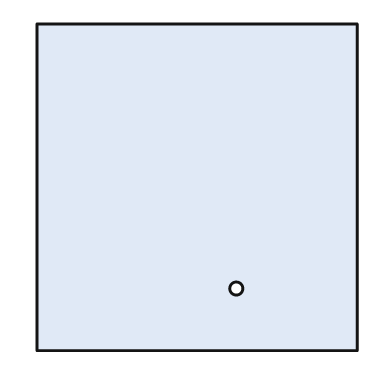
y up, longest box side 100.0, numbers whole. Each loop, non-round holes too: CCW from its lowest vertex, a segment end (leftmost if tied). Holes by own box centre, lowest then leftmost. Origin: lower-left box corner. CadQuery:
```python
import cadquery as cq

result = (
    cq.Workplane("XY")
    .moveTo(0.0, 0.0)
    .lineTo(98.0, 0.0)
    .lineTo(98.0, 100.0)
    .lineTo(0.0, 100.0)
    .close()
    .moveTo(61.0, 19.0)
    .circle(2.0)
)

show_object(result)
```